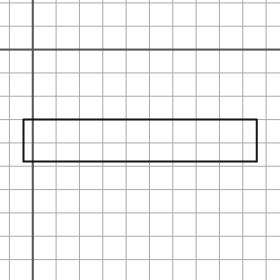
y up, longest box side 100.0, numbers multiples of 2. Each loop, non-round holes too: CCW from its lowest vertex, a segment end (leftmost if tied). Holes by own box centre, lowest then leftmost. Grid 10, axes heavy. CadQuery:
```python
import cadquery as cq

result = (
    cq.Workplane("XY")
    .moveTo(-4.0, -48.0)
    .lineTo(96.0, -48.0)
    .lineTo(96.0, -30.0)
    .lineTo(-4.0, -30.0)
    .close()
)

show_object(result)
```